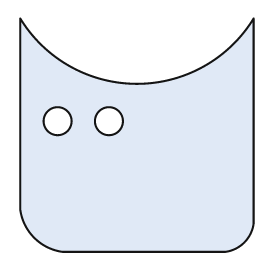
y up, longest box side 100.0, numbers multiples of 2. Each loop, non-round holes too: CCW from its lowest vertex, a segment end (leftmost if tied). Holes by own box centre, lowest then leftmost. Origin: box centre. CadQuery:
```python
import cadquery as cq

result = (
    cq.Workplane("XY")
    .moveTo(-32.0, -50.0)
    .lineTo(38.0, -50.0)
    .threePointArc((46.0, -46.0), (50.0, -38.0))
    .lineTo(50.0, 50.0)
    .threePointArc((0.0, 22.0), (-50.0, 50.0))
    .lineTo(-50.0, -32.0)
    .threePointArc((-44.0, -44.0), (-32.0, -50.0))
    .close()
    .moveTo(-34.0, 6.0)
    .circle(6.0)
    .moveTo(-12.0, 6.0)
    .circle(6.0)
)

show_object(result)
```